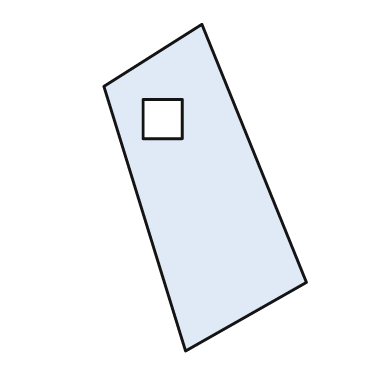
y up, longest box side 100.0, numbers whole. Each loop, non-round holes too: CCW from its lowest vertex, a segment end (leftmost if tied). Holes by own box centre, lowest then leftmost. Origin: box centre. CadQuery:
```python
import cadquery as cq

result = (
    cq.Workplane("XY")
    .moveTo(-6.0, -50.0)
    .lineTo(31.0, -29.0)
    .lineTo(-1.0, 50.0)
    .lineTo(-31.0, 31.0)
    .close()
    .moveTo(-19.0, 15.0)
    .lineTo(-7.0, 15.0)
    .lineTo(-7.0, 27.0)
    .lineTo(-19.0, 27.0)
    .close()
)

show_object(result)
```